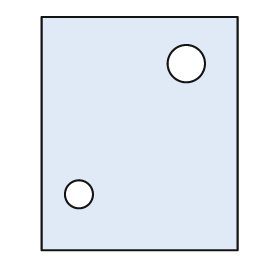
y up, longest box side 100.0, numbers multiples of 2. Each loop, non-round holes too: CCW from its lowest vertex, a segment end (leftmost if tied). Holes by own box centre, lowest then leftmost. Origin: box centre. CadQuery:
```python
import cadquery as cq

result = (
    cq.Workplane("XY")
    .moveTo(-42.0, -50.0)
    .lineTo(42.0, -50.0)
    .lineTo(42.0, 50.0)
    .lineTo(-42.0, 50.0)
    .close()
    .moveTo(-26.0, -26.0)
    .circle(6.0)
    .moveTo(20.0, 30.0)
    .circle(8.0)
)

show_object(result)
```